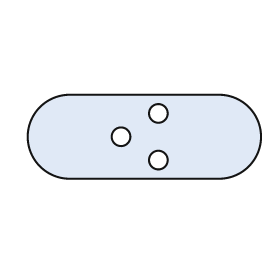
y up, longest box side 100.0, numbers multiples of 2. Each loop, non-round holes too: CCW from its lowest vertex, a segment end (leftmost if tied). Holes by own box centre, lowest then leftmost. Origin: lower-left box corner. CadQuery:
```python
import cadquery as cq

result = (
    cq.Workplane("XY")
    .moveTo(18.0, 0.0)
    .lineTo(82.0, 0.0)
    .threePointArc((100.0, 18.0), (82.0, 36.0))
    .lineTo(18.0, 36.0)
    .threePointArc((0.0, 18.0), (18.0, 0.0))
    .close()
    .moveTo(56.0, 8.0)
    .circle(4.0)
    .moveTo(40.0, 18.0)
    .circle(4.0)
    .moveTo(56.0, 28.0)
    .circle(4.0)
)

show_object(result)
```